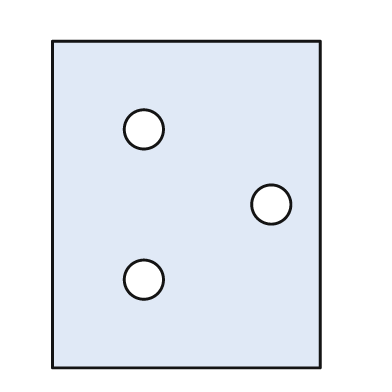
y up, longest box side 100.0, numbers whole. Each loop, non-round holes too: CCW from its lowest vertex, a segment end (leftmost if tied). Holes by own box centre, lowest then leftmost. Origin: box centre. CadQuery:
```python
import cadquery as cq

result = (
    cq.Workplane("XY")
    .moveTo(-41.0, -50.0)
    .lineTo(41.0, -50.0)
    .lineTo(41.0, 50.0)
    .lineTo(-41.0, 50.0)
    .close()
    .moveTo(-13.0, -23.0)
    .circle(6.0)
    .moveTo(26.0, 0.0)
    .circle(6.0)
    .moveTo(-13.0, 23.0)
    .circle(6.0)
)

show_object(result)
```